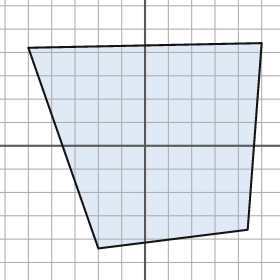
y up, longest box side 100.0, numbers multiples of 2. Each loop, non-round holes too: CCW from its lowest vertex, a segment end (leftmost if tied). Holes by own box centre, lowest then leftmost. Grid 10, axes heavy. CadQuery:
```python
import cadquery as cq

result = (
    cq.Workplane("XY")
    .moveTo(-20.0, -44.0)
    .lineTo(44.0, -36.0)
    .lineTo(50.0, 44.0)
    .lineTo(-50.0, 42.0)
    .close()
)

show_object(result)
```